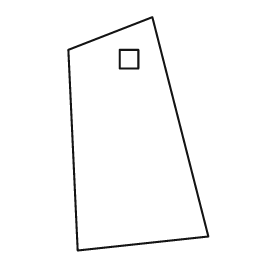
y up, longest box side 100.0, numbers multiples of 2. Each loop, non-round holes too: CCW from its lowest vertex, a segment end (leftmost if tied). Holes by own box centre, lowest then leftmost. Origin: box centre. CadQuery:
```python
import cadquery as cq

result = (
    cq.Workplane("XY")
    .moveTo(-26.0, -50.0)
    .lineTo(30.0, -44.0)
    .lineTo(6.0, 50.0)
    .lineTo(-30.0, 36.0)
    .close()
    .moveTo(-8.0, 28.0)
    .lineTo(0.0, 28.0)
    .lineTo(0.0, 36.0)
    .lineTo(-8.0, 36.0)
    .close()
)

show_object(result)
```